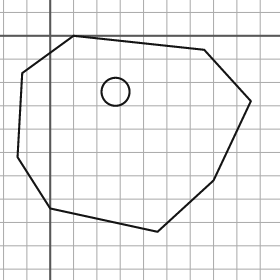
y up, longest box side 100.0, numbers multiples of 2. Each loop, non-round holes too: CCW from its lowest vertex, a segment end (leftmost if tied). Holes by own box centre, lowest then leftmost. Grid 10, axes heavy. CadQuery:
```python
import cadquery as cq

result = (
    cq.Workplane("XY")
    .moveTo(46.0, -84.0)
    .lineTo(70.0, -62.0)
    .lineTo(86.0, -28.0)
    .lineTo(66.0, -6.0)
    .lineTo(10.0, 0.0)
    .lineTo(-12.0, -16.0)
    .lineTo(-14.0, -52.0)
    .lineTo(0.0, -74.0)
    .close()
    .moveTo(28.0, -24.0)
    .circle(6.0)
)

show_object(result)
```